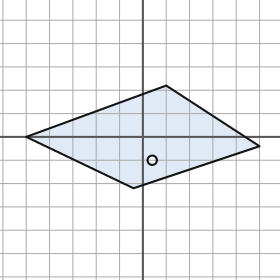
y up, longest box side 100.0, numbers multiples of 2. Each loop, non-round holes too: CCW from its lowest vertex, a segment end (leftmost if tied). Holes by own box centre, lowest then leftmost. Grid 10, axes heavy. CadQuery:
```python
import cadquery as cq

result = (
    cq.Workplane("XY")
    .moveTo(-4.0, -22.0)
    .lineTo(50.0, -4.0)
    .lineTo(10.0, 22.0)
    .lineTo(-50.0, 0.0)
    .close()
    .moveTo(4.0, -10.0)
    .circle(2.0)
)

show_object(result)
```